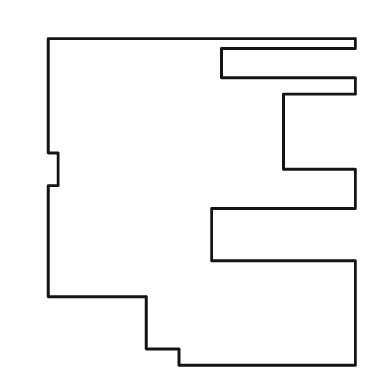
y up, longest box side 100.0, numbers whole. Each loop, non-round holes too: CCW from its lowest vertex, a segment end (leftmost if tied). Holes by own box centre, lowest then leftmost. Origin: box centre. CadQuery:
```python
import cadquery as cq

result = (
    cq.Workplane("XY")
    .moveTo(-7.0, -50.0)
    .lineTo(47.0, -50.0)
    .lineTo(47.0, -18.0)
    .lineTo(3.0, -18.0)
    .lineTo(3.0, -2.0)
    .lineTo(47.0, -2.0)
    .lineTo(47.0, 10.0)
    .lineTo(25.0, 10.0)
    .lineTo(25.0, 33.0)
    .lineTo(47.0, 33.0)
    .lineTo(47.0, 38.0)
    .lineTo(6.0, 38.0)
    .lineTo(6.0, 47.0)
    .lineTo(47.0, 47.0)
    .lineTo(47.0, 50.0)
    .lineTo(-47.0, 50.0)
    .lineTo(-47.0, 15.0)
    .lineTo(-44.0, 15.0)
    .lineTo(-44.0, 5.0)
    .lineTo(-47.0, 5.0)
    .lineTo(-47.0, -29.0)
    .lineTo(-17.0, -29.0)
    .lineTo(-17.0, -45.0)
    .lineTo(-7.0, -45.0)
    .close()
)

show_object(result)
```